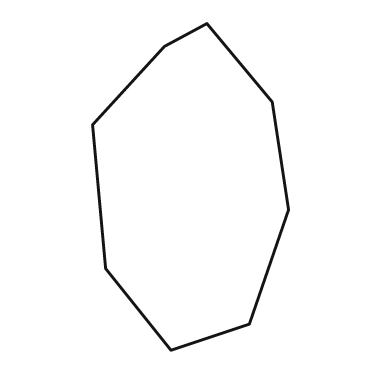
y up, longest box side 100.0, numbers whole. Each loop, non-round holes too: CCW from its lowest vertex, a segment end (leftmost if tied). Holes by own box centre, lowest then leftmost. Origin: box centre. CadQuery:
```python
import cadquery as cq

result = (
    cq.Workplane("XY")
    .moveTo(-6.0, -50.0)
    .lineTo(18.0, -42.0)
    .lineTo(30.0, -7.0)
    .lineTo(25.0, 26.0)
    .lineTo(5.0, 50.0)
    .lineTo(-8.0, 43.0)
    .lineTo(-30.0, 19.0)
    .lineTo(-26.0, -25.0)
    .close()
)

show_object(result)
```